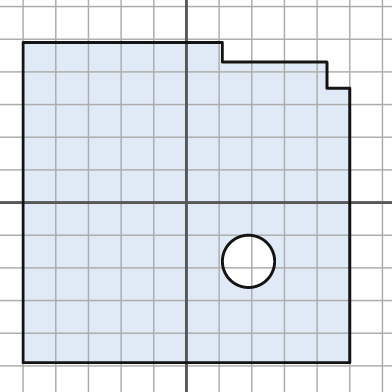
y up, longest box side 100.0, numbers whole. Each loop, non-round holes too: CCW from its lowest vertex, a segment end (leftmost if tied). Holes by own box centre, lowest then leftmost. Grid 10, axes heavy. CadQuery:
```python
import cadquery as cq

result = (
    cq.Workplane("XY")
    .moveTo(-50.0, -49.0)
    .lineTo(50.0, -49.0)
    .lineTo(50.0, 35.0)
    .lineTo(43.0, 35.0)
    .lineTo(43.0, 43.0)
    .lineTo(11.0, 43.0)
    .lineTo(11.0, 49.0)
    .lineTo(-50.0, 49.0)
    .close()
    .moveTo(19.0, -18.0)
    .circle(8.0)
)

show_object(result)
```